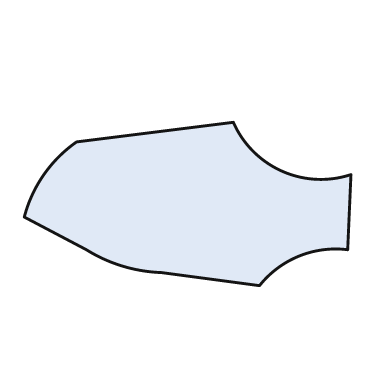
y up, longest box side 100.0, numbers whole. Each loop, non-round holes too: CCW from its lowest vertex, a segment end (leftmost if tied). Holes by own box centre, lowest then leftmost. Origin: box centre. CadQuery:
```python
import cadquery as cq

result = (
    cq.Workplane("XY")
    .moveTo(22.0, -25.0)
    .threePointArc((34.0, -16.0), (49.0, -14.0))
    .lineTo(50.0, 9.0)
    .threePointArc((29.0, 10.0), (14.0, 25.0))
    .lineTo(-34.0, 19.0)
    .threePointArc((-44.0, 9.0), (-50.0, -4.0))
    .lineTo(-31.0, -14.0)
    .threePointArc((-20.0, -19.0), (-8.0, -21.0))
    .close()
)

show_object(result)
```